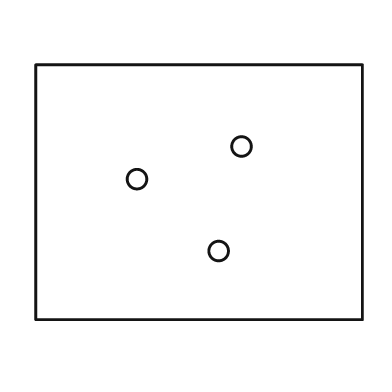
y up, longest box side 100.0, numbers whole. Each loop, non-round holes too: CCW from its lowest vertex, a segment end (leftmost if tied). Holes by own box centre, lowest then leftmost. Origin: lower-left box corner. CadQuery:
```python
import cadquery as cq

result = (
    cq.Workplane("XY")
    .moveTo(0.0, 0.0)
    .lineTo(100.0, 0.0)
    .lineTo(100.0, 78.0)
    .lineTo(0.0, 78.0)
    .close()
    .moveTo(56.0, 21.0)
    .circle(3.0)
    .moveTo(31.0, 43.0)
    .circle(3.0)
    .moveTo(63.0, 53.0)
    .circle(3.0)
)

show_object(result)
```